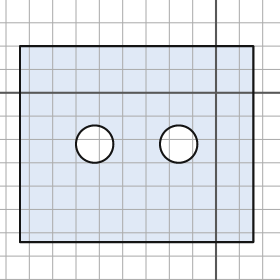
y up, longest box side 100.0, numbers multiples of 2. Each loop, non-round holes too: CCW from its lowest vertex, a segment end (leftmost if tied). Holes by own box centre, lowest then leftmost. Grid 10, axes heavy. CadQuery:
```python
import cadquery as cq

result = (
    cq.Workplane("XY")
    .moveTo(-84.0, -64.0)
    .lineTo(16.0, -64.0)
    .lineTo(16.0, 20.0)
    .lineTo(-84.0, 20.0)
    .close()
    .moveTo(-52.0, -22.0)
    .circle(8.0)
    .moveTo(-16.0, -22.0)
    .circle(8.0)
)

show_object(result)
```